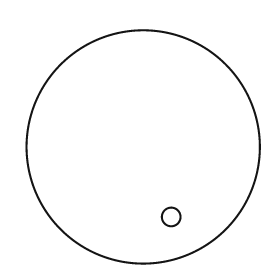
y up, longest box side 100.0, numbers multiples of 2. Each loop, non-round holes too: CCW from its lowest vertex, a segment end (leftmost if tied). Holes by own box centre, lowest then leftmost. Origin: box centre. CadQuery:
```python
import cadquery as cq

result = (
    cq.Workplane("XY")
    .moveTo(0.0, 0.0)
    .circle(50.0)
    .moveTo(12.0, -30.0)
    .circle(4.0)
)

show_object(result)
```